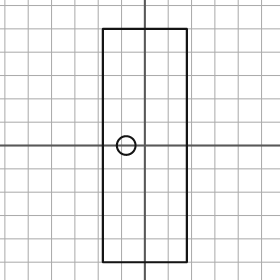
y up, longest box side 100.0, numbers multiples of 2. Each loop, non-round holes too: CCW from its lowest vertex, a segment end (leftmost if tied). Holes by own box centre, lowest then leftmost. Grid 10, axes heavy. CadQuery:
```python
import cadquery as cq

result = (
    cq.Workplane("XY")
    .moveTo(-18.0, -50.0)
    .lineTo(18.0, -50.0)
    .lineTo(18.0, 50.0)
    .lineTo(-18.0, 50.0)
    .close()
    .moveTo(-8.0, 0.0)
    .circle(4.0)
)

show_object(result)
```